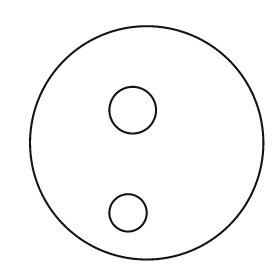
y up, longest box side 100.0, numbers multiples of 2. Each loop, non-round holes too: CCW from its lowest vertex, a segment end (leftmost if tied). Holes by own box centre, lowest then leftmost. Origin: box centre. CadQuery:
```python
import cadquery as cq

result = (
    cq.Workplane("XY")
    .moveTo(0.0, 0.0)
    .circle(50.0)
    .moveTo(-8.0, -30.0)
    .circle(8.0)
    .moveTo(-6.0, 14.0)
    .circle(10.0)
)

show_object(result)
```